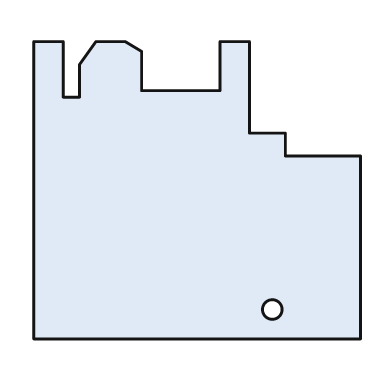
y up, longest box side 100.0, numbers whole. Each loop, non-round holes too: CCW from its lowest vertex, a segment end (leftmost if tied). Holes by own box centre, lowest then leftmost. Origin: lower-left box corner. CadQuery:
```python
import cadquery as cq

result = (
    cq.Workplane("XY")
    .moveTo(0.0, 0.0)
    .lineTo(100.0, 0.0)
    .lineTo(100.0, 56.0)
    .lineTo(77.0, 56.0)
    .lineTo(77.0, 63.0)
    .lineTo(66.0, 63.0)
    .lineTo(66.0, 91.0)
    .lineTo(57.0, 91.0)
    .lineTo(57.0, 76.0)
    .lineTo(33.0, 76.0)
    .lineTo(33.0, 88.0)
    .lineTo(28.0, 91.0)
    .lineTo(19.0, 91.0)
    .lineTo(14.0, 84.0)
    .lineTo(14.0, 74.0)
    .lineTo(9.0, 74.0)
    .lineTo(9.0, 91.0)
    .lineTo(0.0, 91.0)
    .close()
    .moveTo(73.0, 9.0)
    .circle(3.0)
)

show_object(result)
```